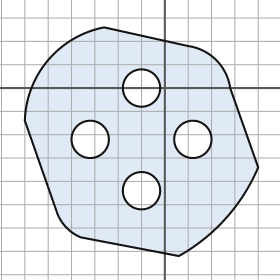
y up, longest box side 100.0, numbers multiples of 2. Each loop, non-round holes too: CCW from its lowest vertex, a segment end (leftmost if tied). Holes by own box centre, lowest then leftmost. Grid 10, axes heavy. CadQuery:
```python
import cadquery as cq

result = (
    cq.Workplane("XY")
    .moveTo(6.0, -72.0)
    .threePointArc((26.0, -56.0), (40.0, -34.0))
    .lineTo(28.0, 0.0)
    .threePointArc((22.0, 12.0), (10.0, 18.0))
    .lineTo(-26.0, 26.0)
    .threePointArc((-50.0, 12.0), (-60.0, -14.0))
    .lineTo(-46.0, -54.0)
    .threePointArc((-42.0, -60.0), (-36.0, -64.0))
    .close()
    .moveTo(-10.0, -44.0)
    .circle(8.0)
    .moveTo(-32.0, -22.0)
    .circle(8.0)
    .moveTo(12.0, -22.0)
    .circle(8.0)
    .moveTo(-10.0, 0.0)
    .circle(8.0)
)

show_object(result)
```